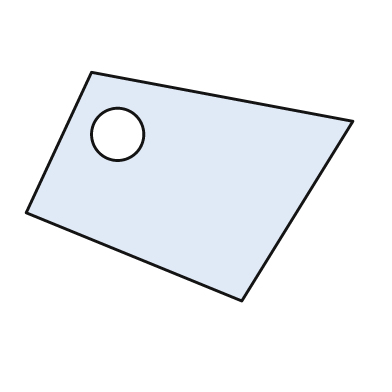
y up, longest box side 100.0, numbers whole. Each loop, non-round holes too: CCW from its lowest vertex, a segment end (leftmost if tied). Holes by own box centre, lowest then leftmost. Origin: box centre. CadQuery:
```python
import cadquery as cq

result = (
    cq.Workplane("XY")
    .moveTo(16.0, -35.0)
    .lineTo(50.0, 20.0)
    .lineTo(-30.0, 35.0)
    .lineTo(-50.0, -8.0)
    .close()
    .moveTo(-22.0, 16.0)
    .circle(8.0)
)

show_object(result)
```